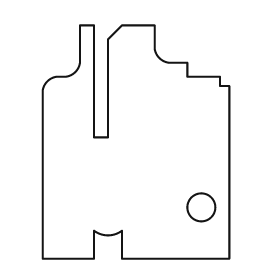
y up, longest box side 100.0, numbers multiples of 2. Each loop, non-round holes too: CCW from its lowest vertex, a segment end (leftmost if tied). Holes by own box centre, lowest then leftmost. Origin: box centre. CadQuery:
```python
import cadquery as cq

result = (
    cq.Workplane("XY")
    .moveTo(-40.0, -50.0)
    .lineTo(-18.0, -50.0)
    .lineTo(-18.0, -38.0)
    .threePointArc((-12.0, -40.0), (-6.0, -38.0))
    .lineTo(-6.0, -50.0)
    .lineTo(40.0, -50.0)
    .lineTo(40.0, 24.0)
    .lineTo(36.0, 24.0)
    .lineTo(36.0, 28.0)
    .lineTo(22.0, 28.0)
    .lineTo(22.0, 34.0)
    .lineTo(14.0, 34.0)
    .threePointArc((10.0, 36.0), (8.0, 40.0))
    .lineTo(8.0, 50.0)
    .lineTo(-6.0, 50.0)
    .lineTo(-12.0, 44.0)
    .lineTo(-12.0, 2.0)
    .lineTo(-18.0, 2.0)
    .lineTo(-18.0, 50.0)
    .lineTo(-24.0, 50.0)
    .lineTo(-24.0, 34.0)
    .threePointArc((-26.0, 30.0), (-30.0, 28.0))
    .lineTo(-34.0, 28.0)
    .threePointArc((-38.0, 26.0), (-40.0, 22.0))
    .close()
    .moveTo(28.0, -28.0)
    .circle(6.0)
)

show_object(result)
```